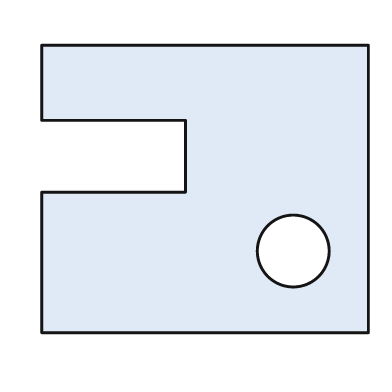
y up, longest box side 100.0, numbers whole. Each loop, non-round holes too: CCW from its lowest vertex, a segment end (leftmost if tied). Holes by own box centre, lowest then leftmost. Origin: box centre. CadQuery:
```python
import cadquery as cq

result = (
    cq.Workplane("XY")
    .moveTo(-50.0, -44.0)
    .lineTo(50.0, -44.0)
    .lineTo(50.0, 44.0)
    .lineTo(-50.0, 44.0)
    .lineTo(-50.0, 21.0)
    .lineTo(-6.0, 21.0)
    .lineTo(-6.0, -1.0)
    .lineTo(-50.0, -1.0)
    .close()
    .moveTo(27.0, -19.0)
    .circle(11.0)
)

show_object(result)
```